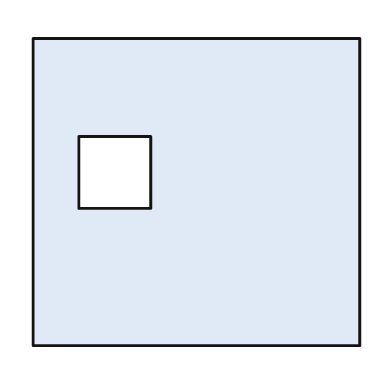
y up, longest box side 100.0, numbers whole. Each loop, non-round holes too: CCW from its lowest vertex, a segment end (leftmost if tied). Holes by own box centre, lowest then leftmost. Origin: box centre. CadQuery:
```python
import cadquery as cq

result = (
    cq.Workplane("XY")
    .moveTo(-50.0, -47.0)
    .lineTo(50.0, -47.0)
    .lineTo(50.0, 47.0)
    .lineTo(-50.0, 47.0)
    .close()
    .moveTo(-36.0, -5.0)
    .lineTo(-14.0, -5.0)
    .lineTo(-14.0, 17.0)
    .lineTo(-36.0, 17.0)
    .close()
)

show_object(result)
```